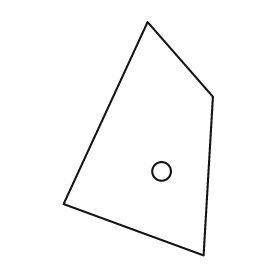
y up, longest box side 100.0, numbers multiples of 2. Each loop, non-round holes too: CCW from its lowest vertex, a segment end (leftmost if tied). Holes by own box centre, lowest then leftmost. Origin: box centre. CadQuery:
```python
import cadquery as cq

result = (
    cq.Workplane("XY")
    .moveTo(28.0, -50.0)
    .lineTo(32.0, 18.0)
    .lineTo(4.0, 50.0)
    .lineTo(-32.0, -28.0)
    .close()
    .moveTo(10.0, -14.0)
    .circle(4.0)
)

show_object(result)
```